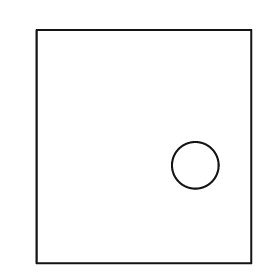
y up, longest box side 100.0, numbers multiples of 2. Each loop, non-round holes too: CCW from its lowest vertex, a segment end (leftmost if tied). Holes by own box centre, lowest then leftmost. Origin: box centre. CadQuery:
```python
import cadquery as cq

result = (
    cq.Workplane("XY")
    .moveTo(-46.0, -50.0)
    .lineTo(46.0, -50.0)
    .lineTo(46.0, 50.0)
    .lineTo(-46.0, 50.0)
    .close()
    .moveTo(22.0, -8.0)
    .circle(10.0)
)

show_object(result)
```